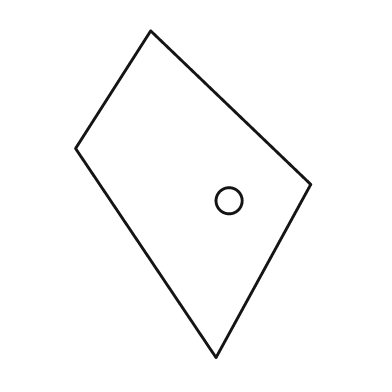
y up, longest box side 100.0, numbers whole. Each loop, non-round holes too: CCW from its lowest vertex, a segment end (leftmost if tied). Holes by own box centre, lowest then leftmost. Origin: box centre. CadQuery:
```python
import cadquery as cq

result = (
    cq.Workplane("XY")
    .moveTo(7.0, -50.0)
    .lineTo(36.0, 3.0)
    .lineTo(-13.0, 50.0)
    .lineTo(-36.0, 14.0)
    .close()
    .moveTo(11.0, -2.0)
    .circle(4.0)
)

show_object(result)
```